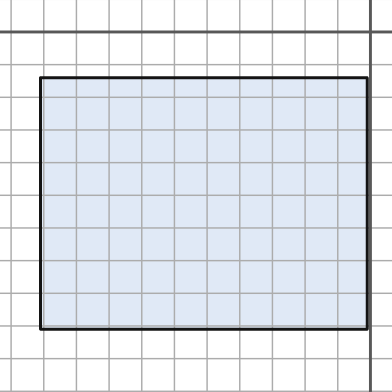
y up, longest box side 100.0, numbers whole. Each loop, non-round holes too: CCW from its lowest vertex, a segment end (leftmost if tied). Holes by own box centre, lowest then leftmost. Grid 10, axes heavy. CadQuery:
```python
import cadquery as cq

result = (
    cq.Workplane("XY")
    .moveTo(-101.0, -91.0)
    .lineTo(-1.0, -91.0)
    .lineTo(-1.0, -14.0)
    .lineTo(-101.0, -14.0)
    .close()
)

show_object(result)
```